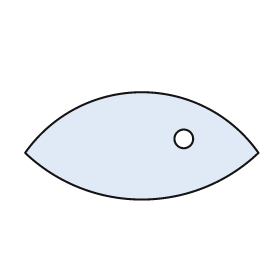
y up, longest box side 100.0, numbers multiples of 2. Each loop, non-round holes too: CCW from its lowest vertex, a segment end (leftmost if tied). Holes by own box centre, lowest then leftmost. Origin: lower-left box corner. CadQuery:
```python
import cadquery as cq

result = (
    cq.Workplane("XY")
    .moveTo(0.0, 20.0)
    .threePointArc((50.0, 0.0), (100.0, 20.0))
    .threePointArc((50.0, 46.0), (0.0, 20.0))
    .close()
    .moveTo(68.0, 26.0)
    .circle(4.0)
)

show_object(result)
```